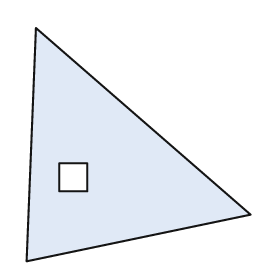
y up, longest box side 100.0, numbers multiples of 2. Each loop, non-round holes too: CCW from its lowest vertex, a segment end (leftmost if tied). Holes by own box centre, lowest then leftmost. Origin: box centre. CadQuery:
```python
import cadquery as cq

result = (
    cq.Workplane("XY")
    .moveTo(-48.0, -50.0)
    .lineTo(48.0, -30.0)
    .lineTo(-44.0, 50.0)
    .close()
    .moveTo(-34.0, -20.0)
    .lineTo(-22.0, -20.0)
    .lineTo(-22.0, -8.0)
    .lineTo(-34.0, -8.0)
    .close()
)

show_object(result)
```